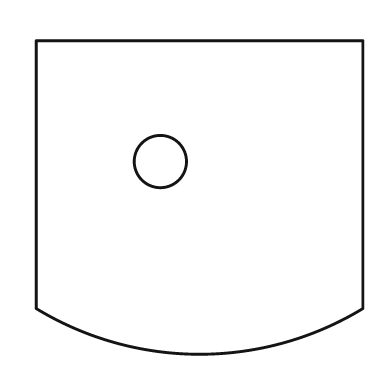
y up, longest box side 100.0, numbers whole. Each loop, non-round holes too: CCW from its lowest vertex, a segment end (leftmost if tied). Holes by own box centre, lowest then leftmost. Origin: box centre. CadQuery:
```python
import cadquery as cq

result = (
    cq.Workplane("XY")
    .moveTo(-50.0, -34.0)
    .threePointArc((0.0, -48.0), (50.0, -34.0))
    .lineTo(50.0, 48.0)
    .lineTo(-50.0, 48.0)
    .close()
    .moveTo(-12.0, 11.0)
    .circle(8.0)
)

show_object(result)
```